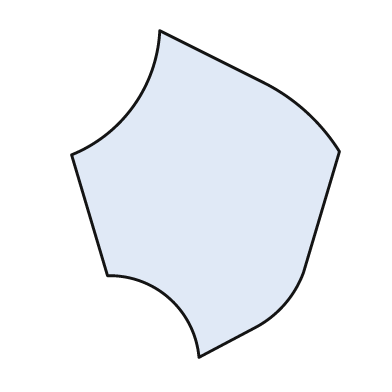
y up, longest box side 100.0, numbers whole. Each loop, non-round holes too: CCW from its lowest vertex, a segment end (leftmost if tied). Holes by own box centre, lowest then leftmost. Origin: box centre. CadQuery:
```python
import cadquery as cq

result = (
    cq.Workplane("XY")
    .moveTo(-2.0, -50.0)
    .lineTo(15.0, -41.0)
    .threePointArc((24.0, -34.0), (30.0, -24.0))
    .lineTo(41.0, 13.0)
    .threePointArc((31.0, 25.0), (18.0, 34.0))
    .lineTo(-14.0, 50.0)
    .threePointArc((-22.0, 27.0), (-41.0, 12.0))
    .lineTo(-30.0, -25.0)
    .threePointArc((-11.0, -32.0), (-2.0, -50.0))
    .close()
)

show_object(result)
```